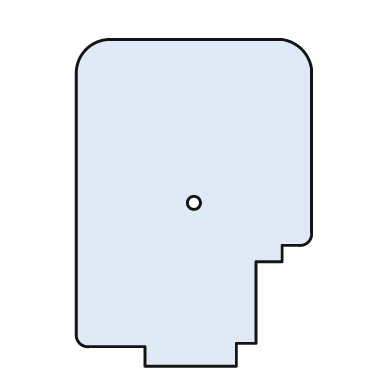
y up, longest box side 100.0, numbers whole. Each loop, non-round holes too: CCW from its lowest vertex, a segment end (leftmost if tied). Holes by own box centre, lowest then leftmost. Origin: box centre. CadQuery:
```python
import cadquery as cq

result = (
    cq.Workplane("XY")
    .moveTo(-15.0, -50.0)
    .lineTo(13.0, -50.0)
    .lineTo(13.0, -43.0)
    .lineTo(19.0, -43.0)
    .lineTo(19.0, -18.0)
    .lineTo(27.0, -18.0)
    .lineTo(27.0, -13.0)
    .lineTo(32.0, -13.0)
    .threePointArc((35.0, -12.0), (36.0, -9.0))
    .lineTo(36.0, 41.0)
    .threePointArc((33.0, 47.0), (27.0, 50.0))
    .lineTo(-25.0, 50.0)
    .threePointArc((-33.0, 47.0), (-36.0, 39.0))
    .lineTo(-36.0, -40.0)
    .threePointArc((-35.0, -43.0), (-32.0, -44.0))
    .lineTo(-15.0, -44.0)
    .close()
    .moveTo(0.0, 0.0)
    .circle(2.0)
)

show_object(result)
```